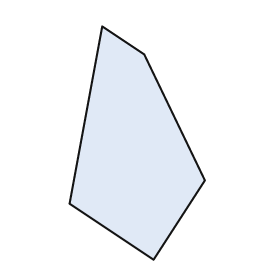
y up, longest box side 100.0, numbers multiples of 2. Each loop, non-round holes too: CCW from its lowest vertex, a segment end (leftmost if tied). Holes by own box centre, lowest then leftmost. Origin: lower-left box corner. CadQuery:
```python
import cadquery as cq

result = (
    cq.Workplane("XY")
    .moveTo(36.0, 0.0)
    .lineTo(58.0, 34.0)
    .lineTo(32.0, 88.0)
    .lineTo(14.0, 100.0)
    .lineTo(0.0, 24.0)
    .close()
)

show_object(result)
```